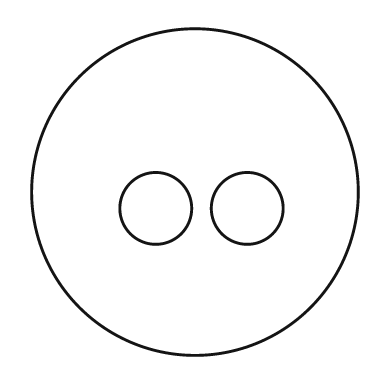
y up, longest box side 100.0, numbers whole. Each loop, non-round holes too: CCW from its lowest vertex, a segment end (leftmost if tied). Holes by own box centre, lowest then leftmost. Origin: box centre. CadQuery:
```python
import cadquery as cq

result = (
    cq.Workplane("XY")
    .moveTo(0.0, 0.0)
    .circle(50.0)
    .moveTo(-12.0, -5.0)
    .circle(11.0)
    .moveTo(16.0, -5.0)
    .circle(11.0)
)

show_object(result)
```